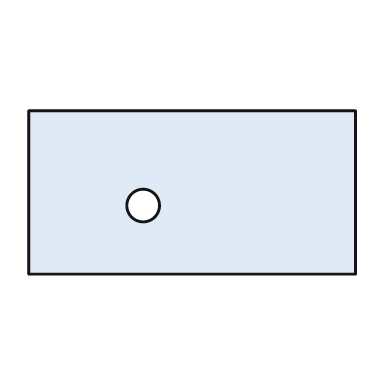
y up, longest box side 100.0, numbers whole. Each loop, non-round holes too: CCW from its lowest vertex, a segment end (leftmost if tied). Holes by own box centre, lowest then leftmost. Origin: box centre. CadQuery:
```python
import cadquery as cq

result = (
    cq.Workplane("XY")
    .moveTo(-50.0, -25.0)
    .lineTo(50.0, -25.0)
    .lineTo(50.0, 25.0)
    .lineTo(-50.0, 25.0)
    .close()
    .moveTo(-15.0, -4.0)
    .circle(5.0)
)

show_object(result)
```